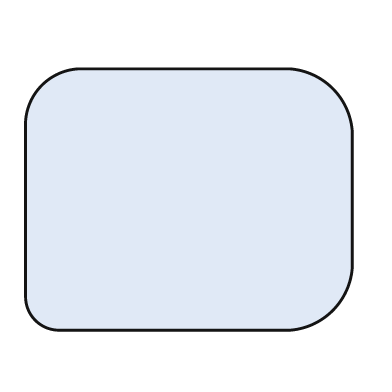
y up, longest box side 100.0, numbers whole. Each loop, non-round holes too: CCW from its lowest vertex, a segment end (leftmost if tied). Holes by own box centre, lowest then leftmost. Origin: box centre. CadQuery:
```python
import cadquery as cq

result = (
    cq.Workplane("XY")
    .moveTo(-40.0, -40.0)
    .lineTo(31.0, -40.0)
    .threePointArc((44.0, -34.0), (50.0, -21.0))
    .lineTo(50.0, 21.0)
    .threePointArc((44.0, 34.0), (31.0, 40.0))
    .lineTo(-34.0, 40.0)
    .threePointArc((-45.0, 35.0), (-50.0, 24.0))
    .lineTo(-50.0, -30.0)
    .threePointArc((-47.0, -37.0), (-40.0, -40.0))
    .close()
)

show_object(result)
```